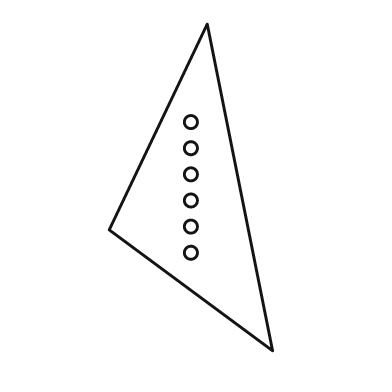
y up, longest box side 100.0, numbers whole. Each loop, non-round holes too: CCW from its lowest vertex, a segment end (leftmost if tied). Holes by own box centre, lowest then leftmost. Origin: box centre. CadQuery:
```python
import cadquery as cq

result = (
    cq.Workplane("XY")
    .moveTo(25.0, -50.0)
    .lineTo(5.0, 50.0)
    .lineTo(-25.0, -13.0)
    .close()
    .moveTo(0.0, -20.0)
    .circle(2.0)
    .moveTo(0.0, -12.0)
    .circle(2.0)
    .moveTo(0.0, -4.0)
    .circle(2.0)
    .moveTo(0.0, 4.0)
    .circle(2.0)
    .moveTo(0.0, 12.0)
    .circle(2.0)
    .moveTo(0.0, 20.0)
    .circle(2.0)
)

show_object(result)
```